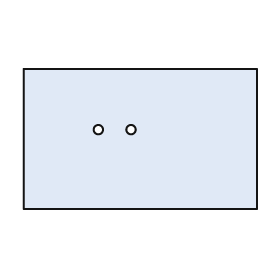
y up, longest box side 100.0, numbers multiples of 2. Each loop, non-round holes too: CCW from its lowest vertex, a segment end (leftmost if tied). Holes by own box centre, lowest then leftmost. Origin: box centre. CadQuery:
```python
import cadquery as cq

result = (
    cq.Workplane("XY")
    .moveTo(-50.0, -30.0)
    .lineTo(50.0, -30.0)
    .lineTo(50.0, 30.0)
    .lineTo(-50.0, 30.0)
    .close()
    .moveTo(-18.0, 4.0)
    .circle(2.0)
    .moveTo(-4.0, 4.0)
    .circle(2.0)
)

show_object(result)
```